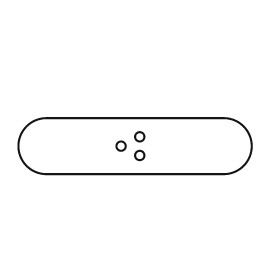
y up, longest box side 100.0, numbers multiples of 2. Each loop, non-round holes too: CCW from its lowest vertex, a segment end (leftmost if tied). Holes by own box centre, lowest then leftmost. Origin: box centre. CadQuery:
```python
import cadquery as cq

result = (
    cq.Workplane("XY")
    .moveTo(-38.0, -12.0)
    .lineTo(38.0, -12.0)
    .threePointArc((50.0, 0.0), (38.0, 12.0))
    .lineTo(-38.0, 12.0)
    .threePointArc((-50.0, 0.0), (-38.0, -12.0))
    .close()
    .moveTo(2.0, -4.0)
    .circle(2.0)
    .moveTo(-6.0, 0.0)
    .circle(2.0)
    .moveTo(2.0, 4.0)
    .circle(2.0)
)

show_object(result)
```